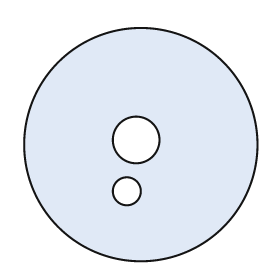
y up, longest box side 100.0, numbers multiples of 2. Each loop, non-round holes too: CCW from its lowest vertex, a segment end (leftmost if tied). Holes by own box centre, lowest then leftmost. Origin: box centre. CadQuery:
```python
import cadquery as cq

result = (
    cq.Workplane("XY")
    .moveTo(0.0, 0.0)
    .circle(50.0)
    .moveTo(-6.0, -20.0)
    .circle(6.0)
    .moveTo(-2.0, 2.0)
    .circle(10.0)
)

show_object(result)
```